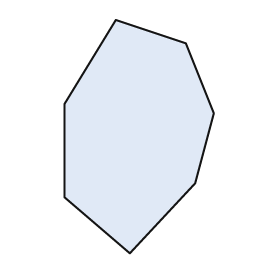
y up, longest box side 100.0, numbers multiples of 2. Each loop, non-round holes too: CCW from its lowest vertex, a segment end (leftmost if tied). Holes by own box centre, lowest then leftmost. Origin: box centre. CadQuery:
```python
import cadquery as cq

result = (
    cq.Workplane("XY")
    .moveTo(-4.0, -50.0)
    .lineTo(24.0, -20.0)
    .lineTo(32.0, 10.0)
    .lineTo(20.0, 40.0)
    .lineTo(-10.0, 50.0)
    .lineTo(-32.0, 14.0)
    .lineTo(-32.0, -26.0)
    .close()
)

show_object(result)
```